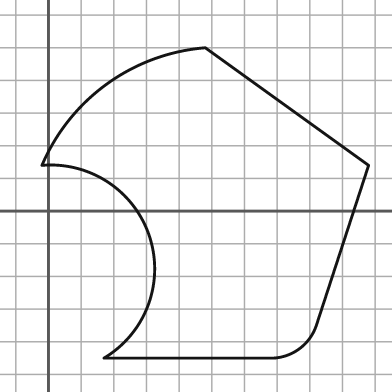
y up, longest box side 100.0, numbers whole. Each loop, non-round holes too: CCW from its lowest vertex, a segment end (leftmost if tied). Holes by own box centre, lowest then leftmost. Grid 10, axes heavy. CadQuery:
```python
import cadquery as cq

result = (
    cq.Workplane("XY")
    .moveTo(17.0, -45.0)
    .lineTo(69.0, -45.0)
    .threePointArc((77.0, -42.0), (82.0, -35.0))
    .lineTo(98.0, 14.0)
    .lineTo(48.0, 50.0)
    .threePointArc((18.0, 39.0), (-2.0, 14.0))
    .threePointArc((31.0, -8.0), (17.0, -45.0))
    .close()
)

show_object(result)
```